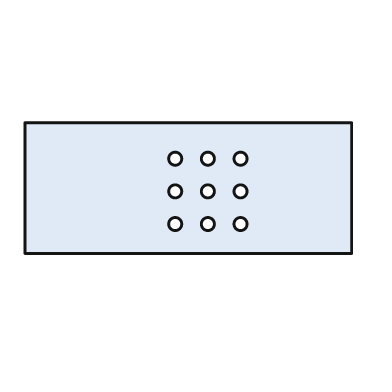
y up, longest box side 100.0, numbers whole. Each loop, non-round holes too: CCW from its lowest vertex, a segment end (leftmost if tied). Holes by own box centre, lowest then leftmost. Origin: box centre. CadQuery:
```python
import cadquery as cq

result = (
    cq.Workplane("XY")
    .moveTo(-50.0, -20.0)
    .lineTo(50.0, -20.0)
    .lineTo(50.0, 20.0)
    .lineTo(-50.0, 20.0)
    .close()
    .moveTo(-4.0, -11.0)
    .circle(2.0)
    .moveTo(6.0, -11.0)
    .circle(2.0)
    .moveTo(16.0, -11.0)
    .circle(2.0)
    .moveTo(-4.0, -1.0)
    .circle(2.0)
    .moveTo(6.0, -1.0)
    .circle(2.0)
    .moveTo(16.0, -1.0)
    .circle(2.0)
    .moveTo(-4.0, 9.0)
    .circle(2.0)
    .moveTo(6.0, 9.0)
    .circle(2.0)
    .moveTo(16.0, 9.0)
    .circle(2.0)
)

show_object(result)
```